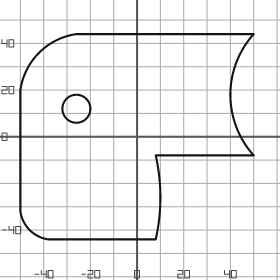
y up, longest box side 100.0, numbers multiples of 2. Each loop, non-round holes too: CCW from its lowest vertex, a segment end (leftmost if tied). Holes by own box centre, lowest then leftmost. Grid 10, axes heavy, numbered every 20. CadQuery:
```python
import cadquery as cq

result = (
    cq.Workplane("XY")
    .moveTo(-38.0, -44.0)
    .lineTo(8.0, -44.0)
    .threePointArc((10.0, -26.0), (8.0, -8.0))
    .lineTo(50.0, -8.0)
    .threePointArc((40.0, 18.0), (50.0, 44.0))
    .lineTo(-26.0, 44.0)
    .threePointArc((-42.0, 36.0), (-50.0, 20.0))
    .lineTo(-50.0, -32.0)
    .threePointArc((-46.0, -40.0), (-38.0, -44.0))
    .close()
    .moveTo(-26.0, 12.0)
    .circle(6.0)
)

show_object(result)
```